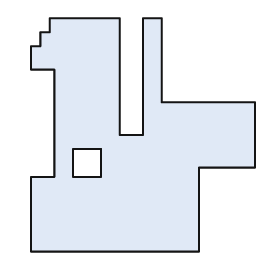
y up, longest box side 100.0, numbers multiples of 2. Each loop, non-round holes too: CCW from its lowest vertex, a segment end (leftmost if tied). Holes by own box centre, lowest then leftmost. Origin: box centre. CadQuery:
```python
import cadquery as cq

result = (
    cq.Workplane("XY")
    .moveTo(-48.0, -50.0)
    .lineTo(24.0, -50.0)
    .lineTo(24.0, -14.0)
    .lineTo(48.0, -14.0)
    .lineTo(48.0, 14.0)
    .lineTo(8.0, 14.0)
    .lineTo(8.0, 50.0)
    .lineTo(0.0, 50.0)
    .lineTo(0.0, 0.0)
    .lineTo(-10.0, 0.0)
    .lineTo(-10.0, 50.0)
    .lineTo(-40.0, 50.0)
    .lineTo(-40.0, 44.0)
    .lineTo(-44.0, 44.0)
    .lineTo(-44.0, 38.0)
    .lineTo(-48.0, 38.0)
    .lineTo(-48.0, 28.0)
    .lineTo(-38.0, 28.0)
    .lineTo(-38.0, -18.0)
    .lineTo(-48.0, -18.0)
    .close()
    .moveTo(-30.0, -18.0)
    .lineTo(-18.0, -18.0)
    .lineTo(-18.0, -6.0)
    .lineTo(-30.0, -6.0)
    .close()
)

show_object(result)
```